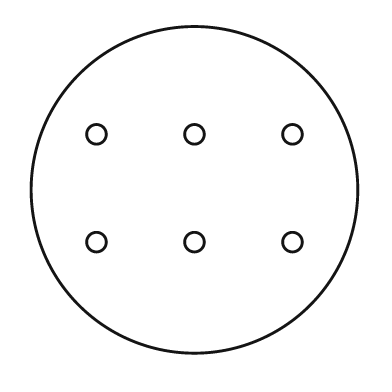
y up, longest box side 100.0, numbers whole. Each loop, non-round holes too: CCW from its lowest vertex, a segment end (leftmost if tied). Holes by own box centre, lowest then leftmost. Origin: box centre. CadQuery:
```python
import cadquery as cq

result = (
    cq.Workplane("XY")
    .moveTo(0.0, 0.0)
    .circle(50.0)
    .moveTo(-30.0, -16.0)
    .circle(3.0)
    .moveTo(0.0, -16.0)
    .circle(3.0)
    .moveTo(30.0, -16.0)
    .circle(3.0)
    .moveTo(-30.0, 17.0)
    .circle(3.0)
    .moveTo(0.0, 17.0)
    .circle(3.0)
    .moveTo(30.0, 17.0)
    .circle(3.0)
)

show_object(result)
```